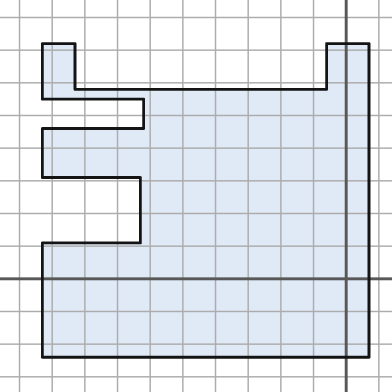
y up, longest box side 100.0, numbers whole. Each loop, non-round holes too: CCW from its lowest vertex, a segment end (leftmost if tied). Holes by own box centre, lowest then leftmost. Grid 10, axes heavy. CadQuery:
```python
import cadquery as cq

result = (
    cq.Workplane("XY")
    .moveTo(-93.0, -24.0)
    .lineTo(7.0, -24.0)
    .lineTo(7.0, 72.0)
    .lineTo(-6.0, 72.0)
    .lineTo(-6.0, 58.0)
    .lineTo(-83.0, 58.0)
    .lineTo(-83.0, 72.0)
    .lineTo(-93.0, 72.0)
    .lineTo(-93.0, 55.0)
    .lineTo(-62.0, 55.0)
    .lineTo(-62.0, 46.0)
    .lineTo(-93.0, 46.0)
    .lineTo(-93.0, 31.0)
    .lineTo(-63.0, 31.0)
    .lineTo(-63.0, 11.0)
    .lineTo(-93.0, 11.0)
    .close()
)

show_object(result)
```